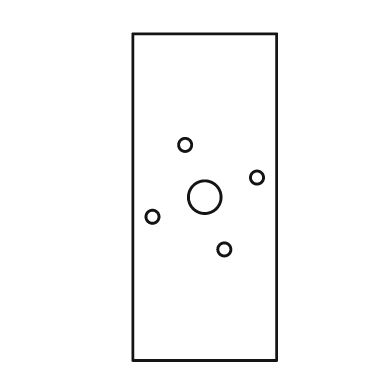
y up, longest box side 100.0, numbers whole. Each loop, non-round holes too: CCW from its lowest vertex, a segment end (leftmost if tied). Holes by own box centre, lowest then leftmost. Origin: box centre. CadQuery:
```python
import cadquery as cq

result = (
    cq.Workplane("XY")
    .moveTo(-22.0, -50.0)
    .lineTo(22.0, -50.0)
    .lineTo(22.0, 50.0)
    .lineTo(-22.0, 50.0)
    .close()
    .moveTo(6.0, -16.0)
    .circle(2.0)
    .moveTo(-16.0, -6.0)
    .circle(2.0)
    .moveTo(0.0, 0.0)
    .circle(5.0)
    .moveTo(16.0, 6.0)
    .circle(2.0)
    .moveTo(-6.0, 16.0)
    .circle(2.0)
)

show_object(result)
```